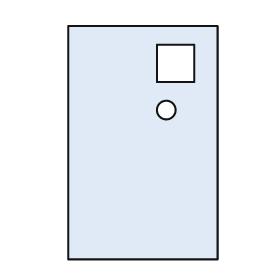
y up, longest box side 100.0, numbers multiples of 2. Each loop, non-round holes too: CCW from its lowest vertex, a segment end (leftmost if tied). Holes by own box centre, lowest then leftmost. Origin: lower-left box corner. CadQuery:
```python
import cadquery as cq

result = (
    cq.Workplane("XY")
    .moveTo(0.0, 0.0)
    .lineTo(64.0, 0.0)
    .lineTo(64.0, 100.0)
    .lineTo(0.0, 100.0)
    .close()
    .moveTo(42.0, 64.0)
    .circle(4.0)
    .moveTo(38.0, 76.0)
    .lineTo(54.0, 76.0)
    .lineTo(54.0, 92.0)
    .lineTo(38.0, 92.0)
    .close()
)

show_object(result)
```